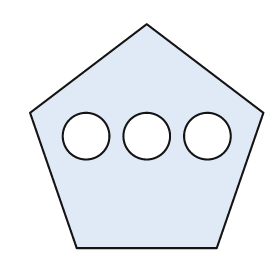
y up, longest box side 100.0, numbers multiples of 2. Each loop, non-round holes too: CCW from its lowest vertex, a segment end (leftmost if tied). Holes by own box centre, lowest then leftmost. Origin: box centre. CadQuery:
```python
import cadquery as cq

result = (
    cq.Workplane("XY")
    .moveTo(-30.0, -48.0)
    .lineTo(30.0, -48.0)
    .lineTo(50.0, 10.0)
    .lineTo(0.0, 48.0)
    .lineTo(-50.0, 10.0)
    .close()
    .moveTo(-26.0, 0.0)
    .circle(10.0)
    .moveTo(0.0, 0.0)
    .circle(10.0)
    .moveTo(26.0, 0.0)
    .circle(10.0)
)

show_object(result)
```